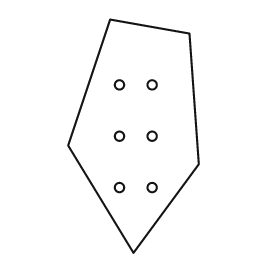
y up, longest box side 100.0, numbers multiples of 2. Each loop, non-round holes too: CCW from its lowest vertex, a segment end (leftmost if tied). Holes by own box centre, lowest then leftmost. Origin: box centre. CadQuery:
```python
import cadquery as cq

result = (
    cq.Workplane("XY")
    .moveTo(0.0, -50.0)
    .lineTo(28.0, -12.0)
    .lineTo(24.0, 44.0)
    .lineTo(-10.0, 50.0)
    .lineTo(-28.0, -4.0)
    .close()
    .moveTo(-6.0, -22.0)
    .circle(2.0)
    .moveTo(8.0, -22.0)
    .circle(2.0)
    .moveTo(-6.0, 0.0)
    .circle(2.0)
    .moveTo(8.0, 0.0)
    .circle(2.0)
    .moveTo(-6.0, 22.0)
    .circle(2.0)
    .moveTo(8.0, 22.0)
    .circle(2.0)
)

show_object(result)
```